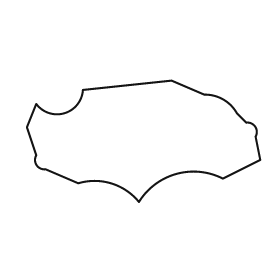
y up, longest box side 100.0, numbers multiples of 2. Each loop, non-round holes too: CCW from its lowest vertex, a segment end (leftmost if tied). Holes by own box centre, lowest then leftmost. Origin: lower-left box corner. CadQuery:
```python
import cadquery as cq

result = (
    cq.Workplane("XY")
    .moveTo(48.0, 0.0)
    .threePointArc((64.0, 12.0), (84.0, 10.0))
    .lineTo(100.0, 18.0)
    .lineTo(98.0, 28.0)
    .threePointArc((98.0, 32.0), (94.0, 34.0))
    .lineTo(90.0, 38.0)
    .threePointArc((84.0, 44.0), (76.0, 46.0))
    .lineTo(62.0, 52.0)
    .lineTo(24.0, 48.0)
    .threePointArc((16.0, 38.0), (4.0, 42.0))
    .lineTo(0.0, 32.0)
    .lineTo(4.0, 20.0)
    .threePointArc((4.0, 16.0), (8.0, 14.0))
    .lineTo(22.0, 8.0)
    .threePointArc((36.0, 8.0), (48.0, 0.0))
    .close()
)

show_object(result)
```